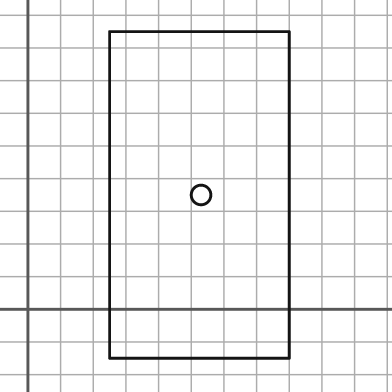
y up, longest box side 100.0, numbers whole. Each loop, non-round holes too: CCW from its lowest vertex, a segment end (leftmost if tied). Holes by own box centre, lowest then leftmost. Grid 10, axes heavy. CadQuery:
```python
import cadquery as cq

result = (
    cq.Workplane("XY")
    .moveTo(25.0, -15.0)
    .lineTo(80.0, -15.0)
    .lineTo(80.0, 85.0)
    .lineTo(25.0, 85.0)
    .close()
    .moveTo(53.0, 35.0)
    .circle(3.0)
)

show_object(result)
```